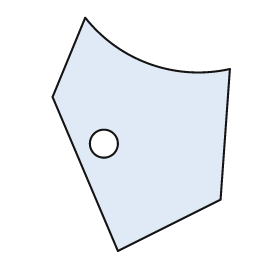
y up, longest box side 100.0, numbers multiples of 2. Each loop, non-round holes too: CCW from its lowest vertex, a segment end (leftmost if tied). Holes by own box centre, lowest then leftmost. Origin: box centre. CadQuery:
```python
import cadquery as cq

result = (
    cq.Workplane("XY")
    .moveTo(-10.0, -50.0)
    .lineTo(34.0, -28.0)
    .lineTo(38.0, 28.0)
    .threePointArc((4.0, 30.0), (-24.0, 50.0))
    .lineTo(-38.0, 16.0)
    .close()
    .moveTo(-16.0, -4.0)
    .circle(6.0)
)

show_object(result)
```